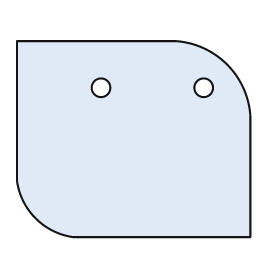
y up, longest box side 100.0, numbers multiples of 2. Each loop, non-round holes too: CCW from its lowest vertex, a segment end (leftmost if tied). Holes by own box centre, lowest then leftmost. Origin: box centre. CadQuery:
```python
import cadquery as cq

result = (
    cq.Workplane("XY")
    .moveTo(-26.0, -42.0)
    .lineTo(50.0, -42.0)
    .lineTo(50.0, 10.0)
    .threePointArc((40.0, 32.0), (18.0, 42.0))
    .lineTo(-50.0, 42.0)
    .lineTo(-50.0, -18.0)
    .threePointArc((-42.0, -34.0), (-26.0, -42.0))
    .close()
    .moveTo(-14.0, 22.0)
    .circle(4.0)
    .moveTo(30.0, 22.0)
    .circle(4.0)
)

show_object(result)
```